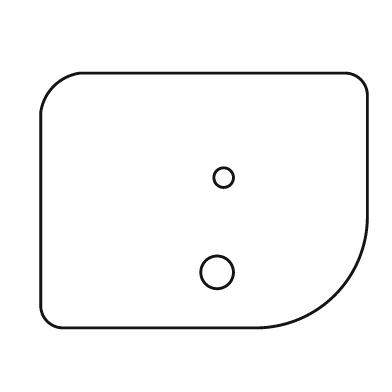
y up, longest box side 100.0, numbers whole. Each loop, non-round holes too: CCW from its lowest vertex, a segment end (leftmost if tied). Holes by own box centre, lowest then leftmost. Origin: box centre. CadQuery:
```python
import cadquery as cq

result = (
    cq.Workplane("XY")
    .moveTo(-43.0, -39.0)
    .lineTo(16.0, -39.0)
    .threePointArc((40.0, -29.0), (50.0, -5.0))
    .lineTo(50.0, 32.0)
    .threePointArc((48.0, 37.0), (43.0, 39.0))
    .lineTo(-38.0, 39.0)
    .threePointArc((-46.0, 35.0), (-50.0, 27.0))
    .lineTo(-50.0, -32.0)
    .threePointArc((-48.0, -37.0), (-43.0, -39.0))
    .close()
    .moveTo(4.0, -22.0)
    .circle(5.0)
    .moveTo(6.0, 7.0)
    .circle(3.0)
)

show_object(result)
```